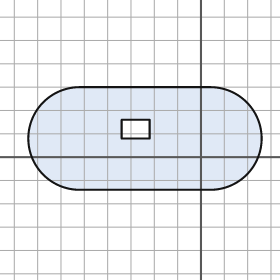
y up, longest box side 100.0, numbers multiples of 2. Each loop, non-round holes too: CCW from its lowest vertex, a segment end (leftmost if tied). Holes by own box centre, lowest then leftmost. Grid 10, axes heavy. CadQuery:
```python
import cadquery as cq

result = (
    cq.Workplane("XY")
    .moveTo(-52.0, -14.0)
    .lineTo(4.0, -14.0)
    .threePointArc((26.0, 8.0), (4.0, 30.0))
    .lineTo(-52.0, 30.0)
    .threePointArc((-74.0, 8.0), (-52.0, -14.0))
    .close()
    .moveTo(-34.0, 8.0)
    .lineTo(-22.0, 8.0)
    .lineTo(-22.0, 16.0)
    .lineTo(-34.0, 16.0)
    .close()
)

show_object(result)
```